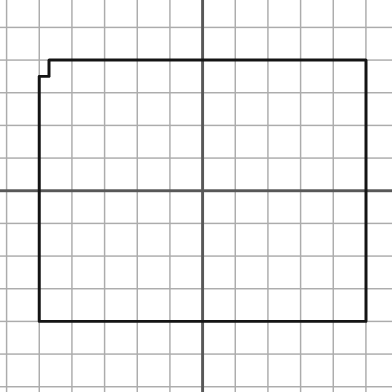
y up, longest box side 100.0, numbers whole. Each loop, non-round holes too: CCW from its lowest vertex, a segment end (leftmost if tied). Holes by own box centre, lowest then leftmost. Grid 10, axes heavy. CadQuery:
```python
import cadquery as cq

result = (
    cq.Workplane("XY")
    .moveTo(-50.0, -40.0)
    .lineTo(50.0, -40.0)
    .lineTo(50.0, 40.0)
    .lineTo(-47.0, 40.0)
    .lineTo(-47.0, 35.0)
    .lineTo(-50.0, 35.0)
    .close()
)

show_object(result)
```